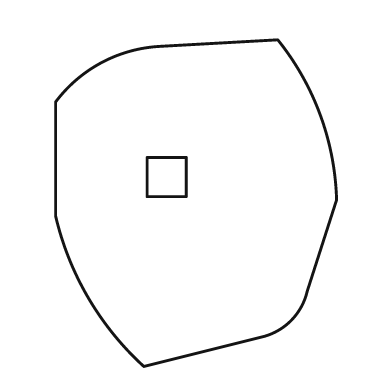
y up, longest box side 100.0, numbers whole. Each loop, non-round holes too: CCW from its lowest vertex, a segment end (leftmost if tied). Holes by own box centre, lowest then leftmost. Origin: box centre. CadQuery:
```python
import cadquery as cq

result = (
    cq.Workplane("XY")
    .moveTo(-16.0, -50.0)
    .lineTo(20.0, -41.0)
    .threePointArc((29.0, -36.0), (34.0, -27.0))
    .lineTo(43.0, 1.0)
    .threePointArc((38.0, 27.0), (25.0, 50.0))
    .lineTo(-11.0, 48.0)
    .threePointArc((-29.0, 43.0), (-43.0, 31.0))
    .lineTo(-43.0, -4.0)
    .threePointArc((-33.0, -29.0), (-16.0, -50.0))
    .close()
    .moveTo(-15.0, 2.0)
    .lineTo(-3.0, 2.0)
    .lineTo(-3.0, 14.0)
    .lineTo(-15.0, 14.0)
    .close()
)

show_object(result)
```